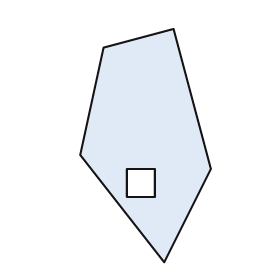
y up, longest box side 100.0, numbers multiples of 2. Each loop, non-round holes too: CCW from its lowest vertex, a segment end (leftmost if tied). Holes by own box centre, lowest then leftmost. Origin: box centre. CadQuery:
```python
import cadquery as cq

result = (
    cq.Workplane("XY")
    .moveTo(8.0, -50.0)
    .lineTo(28.0, -10.0)
    .lineTo(12.0, 50.0)
    .lineTo(-18.0, 42.0)
    .lineTo(-28.0, -4.0)
    .close()
    .moveTo(-8.0, -22.0)
    .lineTo(4.0, -22.0)
    .lineTo(4.0, -10.0)
    .lineTo(-8.0, -10.0)
    .close()
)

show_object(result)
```